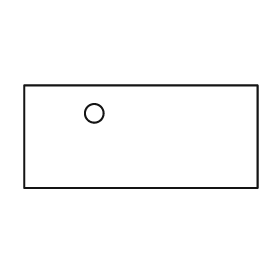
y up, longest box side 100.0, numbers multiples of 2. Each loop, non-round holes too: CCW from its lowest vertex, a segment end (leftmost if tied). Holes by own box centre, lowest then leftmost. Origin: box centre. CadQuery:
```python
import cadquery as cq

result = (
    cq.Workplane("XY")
    .moveTo(-50.0, -22.0)
    .lineTo(50.0, -22.0)
    .lineTo(50.0, 22.0)
    .lineTo(-50.0, 22.0)
    .close()
    .moveTo(-20.0, 10.0)
    .circle(4.0)
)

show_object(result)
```